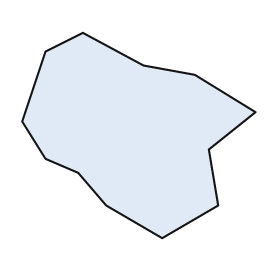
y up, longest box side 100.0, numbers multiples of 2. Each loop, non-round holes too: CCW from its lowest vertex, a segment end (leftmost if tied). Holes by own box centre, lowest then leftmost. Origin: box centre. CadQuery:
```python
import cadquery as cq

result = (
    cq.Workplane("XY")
    .moveTo(10.0, -44.0)
    .lineTo(34.0, -30.0)
    .lineTo(30.0, -6.0)
    .lineTo(50.0, 10.0)
    .lineTo(24.0, 26.0)
    .lineTo(2.0, 30.0)
    .lineTo(-24.0, 44.0)
    .lineTo(-40.0, 36.0)
    .lineTo(-50.0, 6.0)
    .lineTo(-40.0, -10.0)
    .lineTo(-26.0, -16.0)
    .lineTo(-14.0, -30.0)
    .close()
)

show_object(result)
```